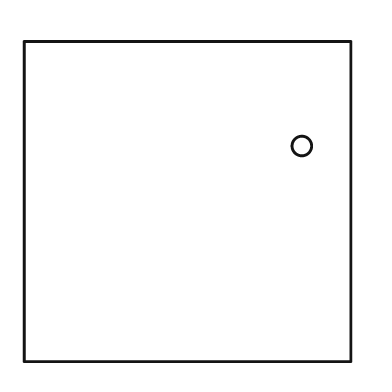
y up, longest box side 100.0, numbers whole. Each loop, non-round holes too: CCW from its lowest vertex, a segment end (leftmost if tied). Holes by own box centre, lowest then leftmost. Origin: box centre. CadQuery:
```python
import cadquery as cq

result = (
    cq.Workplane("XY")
    .moveTo(-50.0, -49.0)
    .lineTo(50.0, -49.0)
    .lineTo(50.0, 49.0)
    .lineTo(-50.0, 49.0)
    .close()
    .moveTo(35.0, 17.0)
    .circle(3.0)
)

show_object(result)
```